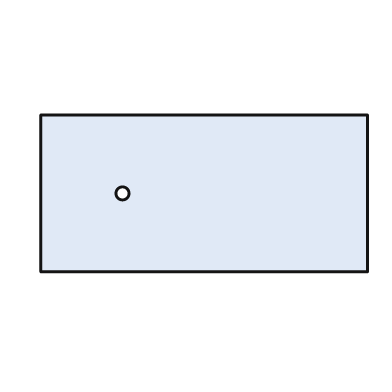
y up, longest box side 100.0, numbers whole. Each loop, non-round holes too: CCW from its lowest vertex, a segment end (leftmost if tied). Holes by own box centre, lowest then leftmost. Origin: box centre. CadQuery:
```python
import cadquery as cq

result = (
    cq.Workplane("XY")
    .moveTo(-50.0, -24.0)
    .lineTo(50.0, -24.0)
    .lineTo(50.0, 24.0)
    .lineTo(-50.0, 24.0)
    .close()
    .moveTo(-25.0, 0.0)
    .circle(2.0)
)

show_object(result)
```